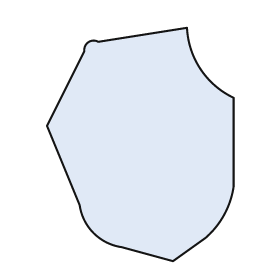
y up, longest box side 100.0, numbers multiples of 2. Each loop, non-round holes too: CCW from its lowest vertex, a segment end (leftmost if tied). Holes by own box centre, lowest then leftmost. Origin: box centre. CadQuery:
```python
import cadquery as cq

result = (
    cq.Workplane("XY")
    .moveTo(14.0, -50.0)
    .lineTo(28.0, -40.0)
    .threePointArc((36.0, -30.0), (40.0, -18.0))
    .lineTo(40.0, 20.0)
    .threePointArc((26.0, 32.0), (20.0, 50.0))
    .lineTo(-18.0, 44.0)
    .threePointArc((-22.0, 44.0), (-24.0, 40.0))
    .lineTo(-40.0, 8.0)
    .lineTo(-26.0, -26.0)
    .threePointArc((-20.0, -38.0), (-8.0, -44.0))
    .close()
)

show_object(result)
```